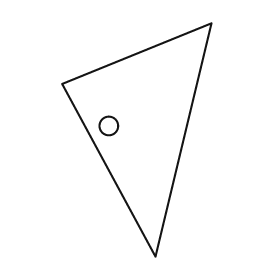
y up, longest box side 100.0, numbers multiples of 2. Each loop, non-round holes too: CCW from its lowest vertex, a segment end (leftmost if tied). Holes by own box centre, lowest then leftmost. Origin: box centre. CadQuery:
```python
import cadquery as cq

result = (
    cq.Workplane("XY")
    .moveTo(8.0, -50.0)
    .lineTo(32.0, 50.0)
    .lineTo(-32.0, 24.0)
    .close()
    .moveTo(-12.0, 6.0)
    .circle(4.0)
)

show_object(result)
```